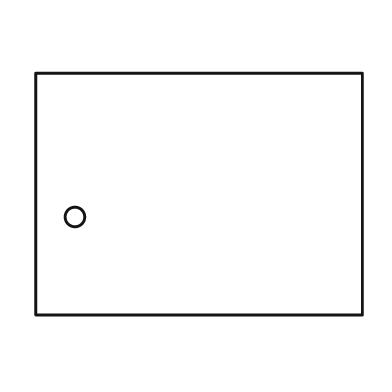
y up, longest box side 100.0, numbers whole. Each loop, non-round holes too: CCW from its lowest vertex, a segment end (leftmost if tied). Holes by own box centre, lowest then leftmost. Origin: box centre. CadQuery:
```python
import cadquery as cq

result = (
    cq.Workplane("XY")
    .moveTo(-50.0, -37.0)
    .lineTo(50.0, -37.0)
    .lineTo(50.0, 37.0)
    .lineTo(-50.0, 37.0)
    .close()
    .moveTo(-38.0, -7.0)
    .circle(3.0)
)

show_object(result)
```